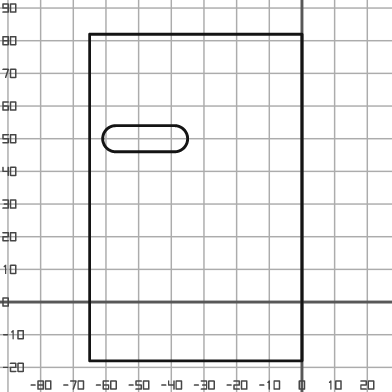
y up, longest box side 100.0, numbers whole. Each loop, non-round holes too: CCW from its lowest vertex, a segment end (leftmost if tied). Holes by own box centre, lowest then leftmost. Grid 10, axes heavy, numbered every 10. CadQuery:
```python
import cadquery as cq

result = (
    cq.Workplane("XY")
    .moveTo(-65.0, -18.0)
    .lineTo(0.0, -18.0)
    .lineTo(0.0, 82.0)
    .lineTo(-65.0, 82.0)
    .close()
    .moveTo(-57.0, 46.0)
    .lineTo(-39.0, 46.0)
    .threePointArc((-35.0, 50.0), (-39.0, 54.0))
    .lineTo(-57.0, 54.0)
    .threePointArc((-61.0, 50.0), (-57.0, 46.0))
    .close()
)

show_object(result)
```